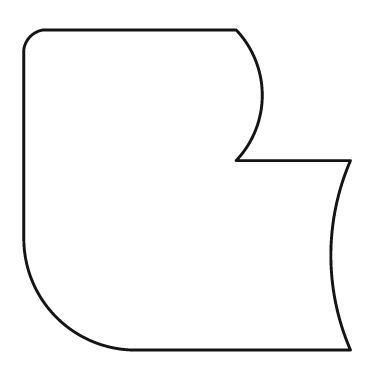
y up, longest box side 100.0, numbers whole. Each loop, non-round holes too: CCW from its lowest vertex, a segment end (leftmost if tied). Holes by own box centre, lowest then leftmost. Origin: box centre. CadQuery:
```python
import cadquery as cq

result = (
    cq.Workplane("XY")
    .moveTo(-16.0, -49.0)
    .lineTo(50.0, -49.0)
    .threePointArc((44.0, -20.0), (50.0, 9.0))
    .lineTo(15.0, 9.0)
    .threePointArc((23.0, 29.0), (15.0, 49.0))
    .lineTo(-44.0, 49.0)
    .threePointArc((-48.0, 47.0), (-50.0, 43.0))
    .lineTo(-50.0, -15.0)
    .threePointArc((-40.0, -39.0), (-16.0, -49.0))
    .close()
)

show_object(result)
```